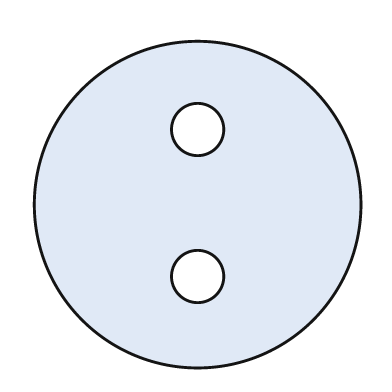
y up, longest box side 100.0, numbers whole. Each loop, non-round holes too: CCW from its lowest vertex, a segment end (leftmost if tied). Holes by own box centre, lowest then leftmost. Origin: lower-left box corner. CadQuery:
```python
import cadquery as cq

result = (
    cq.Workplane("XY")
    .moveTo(50.0, 50.0)
    .circle(50.0)
    .moveTo(50.0, 28.0)
    .circle(8.0)
    .moveTo(50.0, 73.0)
    .circle(8.0)
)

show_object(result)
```